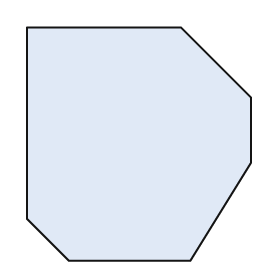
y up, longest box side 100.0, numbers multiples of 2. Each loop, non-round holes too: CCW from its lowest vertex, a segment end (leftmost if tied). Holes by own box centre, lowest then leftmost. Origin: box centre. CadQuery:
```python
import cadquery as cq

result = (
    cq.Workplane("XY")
    .moveTo(-30.0, -50.0)
    .lineTo(22.0, -50.0)
    .lineTo(48.0, -8.0)
    .lineTo(48.0, 20.0)
    .lineTo(18.0, 50.0)
    .lineTo(-48.0, 50.0)
    .lineTo(-48.0, -32.0)
    .close()
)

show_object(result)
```